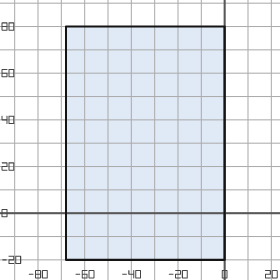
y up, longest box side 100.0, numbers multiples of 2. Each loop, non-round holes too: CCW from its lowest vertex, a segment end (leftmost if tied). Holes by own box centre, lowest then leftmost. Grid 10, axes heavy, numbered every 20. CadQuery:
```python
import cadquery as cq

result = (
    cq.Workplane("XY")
    .moveTo(-68.0, -20.0)
    .lineTo(0.0, -20.0)
    .lineTo(0.0, 80.0)
    .lineTo(-68.0, 80.0)
    .close()
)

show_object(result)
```